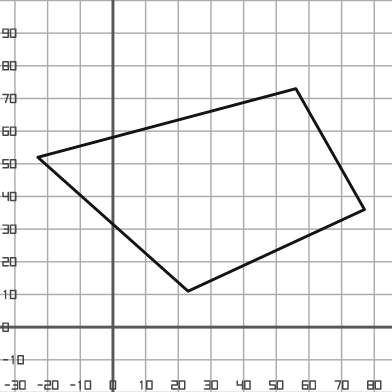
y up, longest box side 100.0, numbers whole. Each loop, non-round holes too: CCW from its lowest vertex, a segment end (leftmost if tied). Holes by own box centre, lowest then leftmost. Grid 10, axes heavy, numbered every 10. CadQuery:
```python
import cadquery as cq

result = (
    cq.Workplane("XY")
    .moveTo(23.0, 11.0)
    .lineTo(77.0, 36.0)
    .lineTo(56.0, 73.0)
    .lineTo(-23.0, 52.0)
    .close()
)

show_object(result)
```